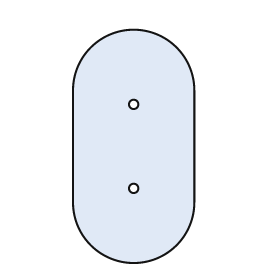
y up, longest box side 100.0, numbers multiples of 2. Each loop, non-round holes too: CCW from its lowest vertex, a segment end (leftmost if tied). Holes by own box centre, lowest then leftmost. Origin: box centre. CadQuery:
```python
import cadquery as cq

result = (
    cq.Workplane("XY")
    .moveTo(-26.0, -24.0)
    .threePointArc((0.0, -50.0), (26.0, -24.0))
    .lineTo(26.0, 24.0)
    .threePointArc((0.0, 50.0), (-26.0, 24.0))
    .close()
    .moveTo(0.0, -18.0)
    .circle(2.0)
    .moveTo(0.0, 18.0)
    .circle(2.0)
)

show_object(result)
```